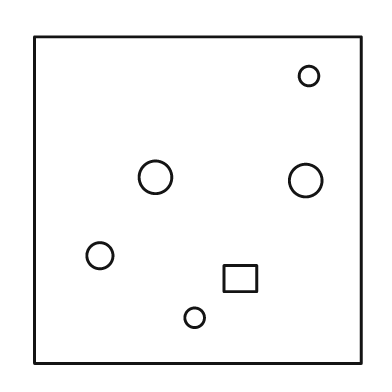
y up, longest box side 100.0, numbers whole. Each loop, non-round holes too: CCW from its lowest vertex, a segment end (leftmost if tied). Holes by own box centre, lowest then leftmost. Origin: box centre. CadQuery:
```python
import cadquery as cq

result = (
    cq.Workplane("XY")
    .moveTo(-50.0, -50.0)
    .lineTo(50.0, -50.0)
    .lineTo(50.0, 50.0)
    .lineTo(-50.0, 50.0)
    .close()
    .moveTo(-1.0, -36.0)
    .circle(3.0)
    .moveTo(8.0, -28.0)
    .lineTo(18.0, -28.0)
    .lineTo(18.0, -20.0)
    .lineTo(8.0, -20.0)
    .close()
    .moveTo(-30.0, -17.0)
    .circle(4.0)
    .moveTo(33.0, 6.0)
    .circle(5.0)
    .moveTo(-13.0, 7.0)
    .circle(5.0)
    .moveTo(34.0, 38.0)
    .circle(3.0)
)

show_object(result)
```